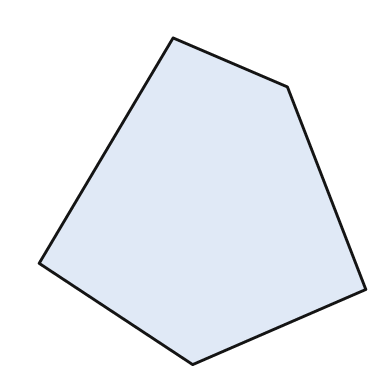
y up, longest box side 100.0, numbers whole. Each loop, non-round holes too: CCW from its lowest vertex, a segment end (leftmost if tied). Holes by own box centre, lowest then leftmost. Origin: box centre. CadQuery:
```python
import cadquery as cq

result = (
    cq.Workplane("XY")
    .moveTo(-3.0, -50.0)
    .lineTo(50.0, -27.0)
    .lineTo(26.0, 35.0)
    .lineTo(-9.0, 50.0)
    .lineTo(-50.0, -19.0)
    .close()
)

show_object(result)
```